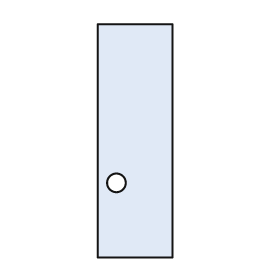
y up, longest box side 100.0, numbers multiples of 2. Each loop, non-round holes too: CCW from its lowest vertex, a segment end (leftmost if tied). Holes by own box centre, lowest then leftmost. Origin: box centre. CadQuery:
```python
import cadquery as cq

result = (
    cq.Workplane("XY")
    .moveTo(-16.0, -50.0)
    .lineTo(16.0, -50.0)
    .lineTo(16.0, 50.0)
    .lineTo(-16.0, 50.0)
    .close()
    .moveTo(-8.0, -18.0)
    .circle(4.0)
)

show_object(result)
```